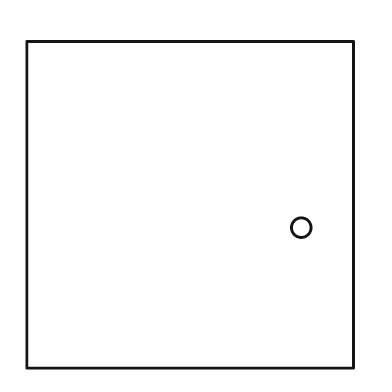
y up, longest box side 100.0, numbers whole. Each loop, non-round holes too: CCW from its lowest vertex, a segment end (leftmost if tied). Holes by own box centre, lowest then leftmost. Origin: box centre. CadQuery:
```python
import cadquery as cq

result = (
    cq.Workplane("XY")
    .moveTo(-50.0, -50.0)
    .lineTo(50.0, -50.0)
    .lineTo(50.0, 50.0)
    .lineTo(-50.0, 50.0)
    .close()
    .moveTo(34.0, -7.0)
    .circle(3.0)
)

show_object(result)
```